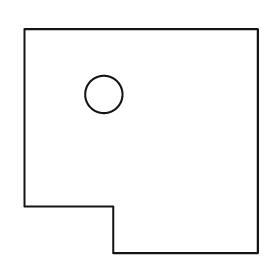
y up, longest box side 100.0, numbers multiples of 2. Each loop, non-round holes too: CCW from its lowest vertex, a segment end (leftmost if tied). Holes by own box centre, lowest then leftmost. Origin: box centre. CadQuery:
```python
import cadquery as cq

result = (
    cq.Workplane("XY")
    .moveTo(-12.0, -48.0)
    .lineTo(50.0, -48.0)
    .lineTo(50.0, 48.0)
    .lineTo(-50.0, 48.0)
    .lineTo(-50.0, -28.0)
    .lineTo(-12.0, -28.0)
    .close()
    .moveTo(-16.0, 20.0)
    .circle(8.0)
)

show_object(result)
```